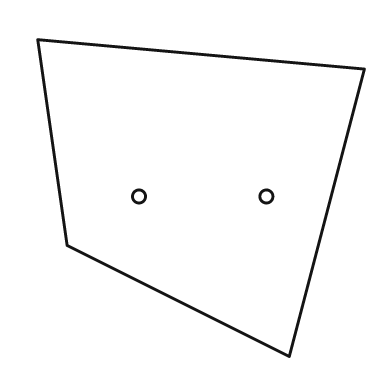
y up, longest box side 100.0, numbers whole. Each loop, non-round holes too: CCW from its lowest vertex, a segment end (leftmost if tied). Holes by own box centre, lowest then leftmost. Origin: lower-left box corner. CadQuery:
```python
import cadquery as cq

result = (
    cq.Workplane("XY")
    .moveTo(77.0, 0.0)
    .lineTo(100.0, 88.0)
    .lineTo(0.0, 97.0)
    .lineTo(9.0, 34.0)
    .close()
    .moveTo(31.0, 49.0)
    .circle(2.0)
    .moveTo(70.0, 49.0)
    .circle(2.0)
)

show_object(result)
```